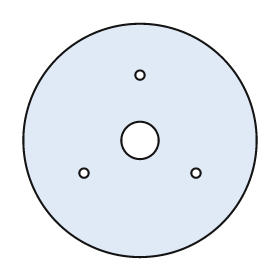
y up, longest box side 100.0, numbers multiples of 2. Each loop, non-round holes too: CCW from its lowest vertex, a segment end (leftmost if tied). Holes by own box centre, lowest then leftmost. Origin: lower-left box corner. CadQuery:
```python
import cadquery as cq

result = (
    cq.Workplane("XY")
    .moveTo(50.0, 50.0)
    .circle(50.0)
    .moveTo(26.0, 36.0)
    .circle(2.0)
    .moveTo(74.0, 36.0)
    .circle(2.0)
    .moveTo(50.0, 50.0)
    .circle(8.0)
    .moveTo(50.0, 78.0)
    .circle(2.0)
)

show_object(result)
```